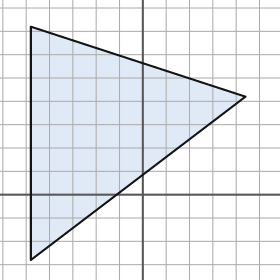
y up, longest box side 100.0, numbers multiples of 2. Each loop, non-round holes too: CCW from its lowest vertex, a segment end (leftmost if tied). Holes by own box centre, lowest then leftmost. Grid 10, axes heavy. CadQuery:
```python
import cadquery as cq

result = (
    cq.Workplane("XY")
    .moveTo(-48.0, -28.0)
    .lineTo(44.0, 42.0)
    .lineTo(-48.0, 72.0)
    .close()
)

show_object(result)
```